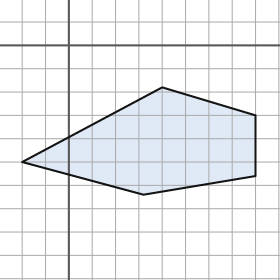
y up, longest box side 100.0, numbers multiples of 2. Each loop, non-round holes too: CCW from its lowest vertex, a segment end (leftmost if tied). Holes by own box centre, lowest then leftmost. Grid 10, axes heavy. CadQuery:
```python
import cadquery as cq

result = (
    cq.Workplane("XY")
    .moveTo(32.0, -64.0)
    .lineTo(80.0, -56.0)
    .lineTo(80.0, -30.0)
    .lineTo(40.0, -18.0)
    .lineTo(-20.0, -50.0)
    .close()
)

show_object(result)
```